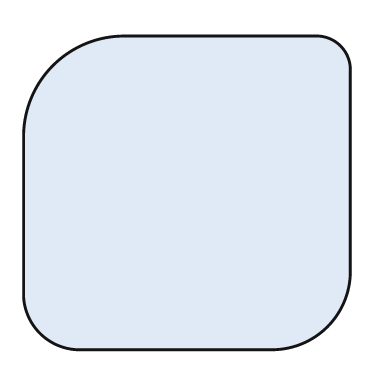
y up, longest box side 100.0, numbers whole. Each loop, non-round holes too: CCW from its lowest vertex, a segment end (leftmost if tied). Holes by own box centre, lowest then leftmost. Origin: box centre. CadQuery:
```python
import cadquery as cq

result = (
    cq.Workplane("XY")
    .moveTo(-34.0, -48.0)
    .lineTo(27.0, -48.0)
    .threePointArc((43.0, -41.0), (50.0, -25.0))
    .lineTo(50.0, 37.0)
    .threePointArc((47.0, 45.0), (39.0, 48.0))
    .lineTo(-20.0, 48.0)
    .threePointArc((-41.0, 39.0), (-50.0, 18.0))
    .lineTo(-50.0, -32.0)
    .threePointArc((-45.0, -43.0), (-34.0, -48.0))
    .close()
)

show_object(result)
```